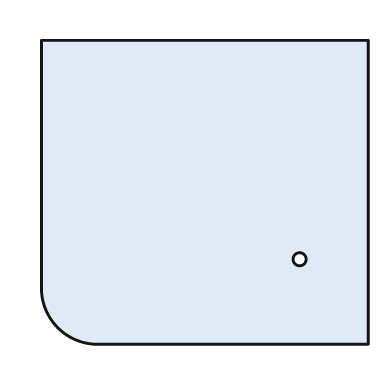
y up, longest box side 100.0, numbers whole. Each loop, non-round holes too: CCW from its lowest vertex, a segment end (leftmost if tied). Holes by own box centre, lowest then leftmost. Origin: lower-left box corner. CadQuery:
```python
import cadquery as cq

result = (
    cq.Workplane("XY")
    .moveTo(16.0, 0.0)
    .lineTo(100.0, 0.0)
    .lineTo(100.0, 93.0)
    .lineTo(0.0, 93.0)
    .lineTo(0.0, 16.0)
    .threePointArc((5.0, 5.0), (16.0, 0.0))
    .close()
    .moveTo(79.0, 26.0)
    .circle(2.0)
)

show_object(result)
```